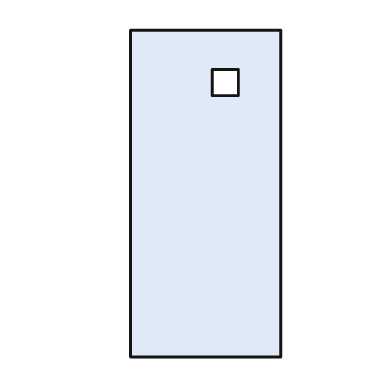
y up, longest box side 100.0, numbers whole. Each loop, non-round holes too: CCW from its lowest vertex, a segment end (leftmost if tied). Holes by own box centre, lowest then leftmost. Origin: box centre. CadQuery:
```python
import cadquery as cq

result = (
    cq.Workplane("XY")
    .moveTo(-23.0, -50.0)
    .lineTo(23.0, -50.0)
    .lineTo(23.0, 50.0)
    .lineTo(-23.0, 50.0)
    .close()
    .moveTo(2.0, 30.0)
    .lineTo(10.0, 30.0)
    .lineTo(10.0, 38.0)
    .lineTo(2.0, 38.0)
    .close()
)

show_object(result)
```